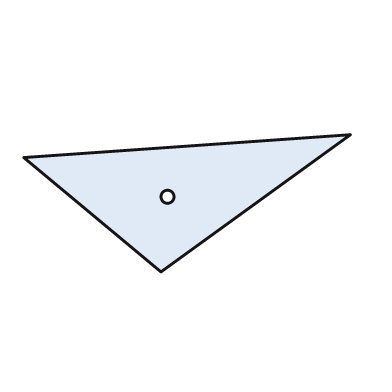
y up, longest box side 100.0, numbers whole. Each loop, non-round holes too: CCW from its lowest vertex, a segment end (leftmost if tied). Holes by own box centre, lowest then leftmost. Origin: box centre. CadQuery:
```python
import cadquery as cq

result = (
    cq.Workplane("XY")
    .moveTo(-8.0, -21.0)
    .lineTo(50.0, 21.0)
    .lineTo(-50.0, 14.0)
    .close()
    .moveTo(-6.0, 2.0)
    .circle(2.0)
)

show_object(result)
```